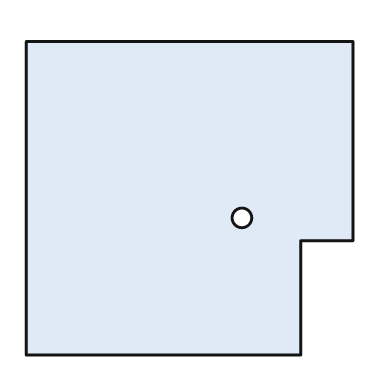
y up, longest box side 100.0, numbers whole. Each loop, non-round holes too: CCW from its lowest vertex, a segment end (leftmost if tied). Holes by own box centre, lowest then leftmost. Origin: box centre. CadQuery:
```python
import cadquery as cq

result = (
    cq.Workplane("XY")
    .moveTo(-50.0, -48.0)
    .lineTo(34.0, -48.0)
    .lineTo(34.0, -13.0)
    .lineTo(50.0, -13.0)
    .lineTo(50.0, 48.0)
    .lineTo(-50.0, 48.0)
    .close()
    .moveTo(16.0, -6.0)
    .circle(3.0)
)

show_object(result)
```